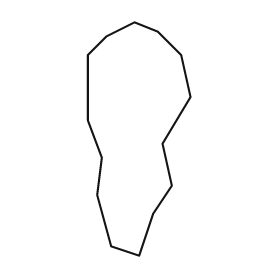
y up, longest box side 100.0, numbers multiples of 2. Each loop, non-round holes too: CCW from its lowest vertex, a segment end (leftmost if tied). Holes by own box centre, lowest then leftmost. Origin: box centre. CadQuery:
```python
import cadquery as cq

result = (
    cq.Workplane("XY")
    .moveTo(0.0, -50.0)
    .lineTo(6.0, -32.0)
    .lineTo(14.0, -20.0)
    .lineTo(10.0, -2.0)
    .lineTo(22.0, 18.0)
    .lineTo(18.0, 36.0)
    .lineTo(8.0, 46.0)
    .lineTo(-2.0, 50.0)
    .lineTo(-14.0, 44.0)
    .lineTo(-22.0, 36.0)
    .lineTo(-22.0, 8.0)
    .lineTo(-16.0, -8.0)
    .lineTo(-18.0, -24.0)
    .lineTo(-12.0, -46.0)
    .close()
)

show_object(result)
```